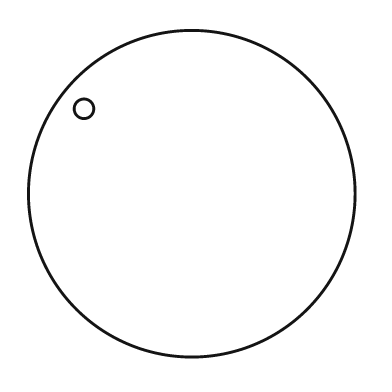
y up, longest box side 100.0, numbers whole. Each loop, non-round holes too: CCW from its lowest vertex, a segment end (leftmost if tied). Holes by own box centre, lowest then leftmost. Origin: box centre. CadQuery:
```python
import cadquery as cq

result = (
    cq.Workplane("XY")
    .moveTo(0.0, 0.0)
    .circle(50.0)
    .moveTo(-33.0, 26.0)
    .circle(3.0)
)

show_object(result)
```